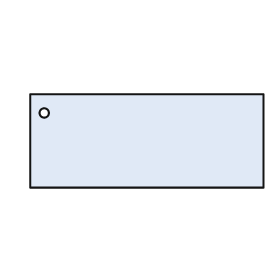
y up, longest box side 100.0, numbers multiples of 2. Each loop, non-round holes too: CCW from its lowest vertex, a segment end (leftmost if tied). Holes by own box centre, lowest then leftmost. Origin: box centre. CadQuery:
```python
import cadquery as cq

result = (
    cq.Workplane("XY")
    .moveTo(-50.0, -20.0)
    .lineTo(50.0, -20.0)
    .lineTo(50.0, 20.0)
    .lineTo(-50.0, 20.0)
    .close()
    .moveTo(-44.0, 12.0)
    .circle(2.0)
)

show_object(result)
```